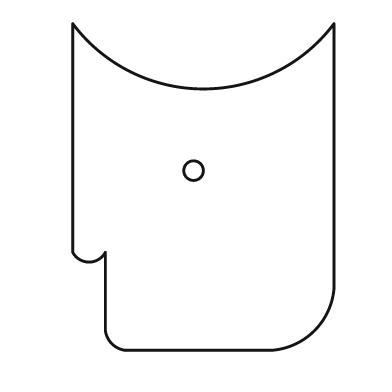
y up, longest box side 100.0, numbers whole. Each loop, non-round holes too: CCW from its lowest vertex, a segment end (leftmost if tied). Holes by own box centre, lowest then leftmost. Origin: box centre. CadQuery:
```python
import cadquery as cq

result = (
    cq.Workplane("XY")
    .moveTo(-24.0, -50.0)
    .lineTo(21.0, -50.0)
    .threePointArc((34.0, -44.0), (40.0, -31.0))
    .lineTo(40.0, 50.0)
    .threePointArc((0.0, 30.0), (-40.0, 50.0))
    .lineTo(-40.0, -20.0)
    .threePointArc((-35.0, -23.0), (-30.0, -20.0))
    .lineTo(-30.0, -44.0)
    .threePointArc((-28.0, -48.0), (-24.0, -50.0))
    .close()
    .moveTo(-3.0, 5.0)
    .circle(3.0)
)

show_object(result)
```